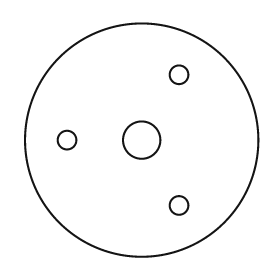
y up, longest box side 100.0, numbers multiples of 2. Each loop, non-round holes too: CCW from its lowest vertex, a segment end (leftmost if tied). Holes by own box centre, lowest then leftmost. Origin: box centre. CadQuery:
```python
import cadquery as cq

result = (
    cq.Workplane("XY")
    .moveTo(0.0, 0.0)
    .circle(50.0)
    .moveTo(16.0, -28.0)
    .circle(4.0)
    .moveTo(-32.0, 0.0)
    .circle(4.0)
    .moveTo(0.0, 0.0)
    .circle(8.0)
    .moveTo(16.0, 28.0)
    .circle(4.0)
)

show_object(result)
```